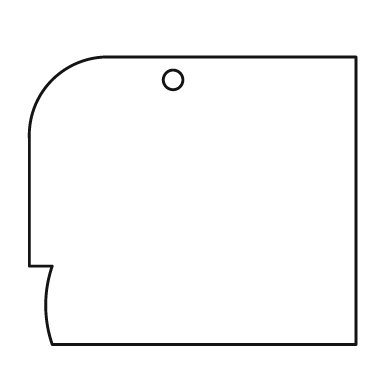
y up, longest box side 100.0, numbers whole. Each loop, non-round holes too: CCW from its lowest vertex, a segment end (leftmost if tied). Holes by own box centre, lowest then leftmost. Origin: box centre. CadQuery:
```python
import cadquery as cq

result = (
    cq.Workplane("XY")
    .moveTo(-43.0, -44.0)
    .lineTo(50.0, -44.0)
    .lineTo(50.0, 44.0)
    .lineTo(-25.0, 44.0)
    .threePointArc((-43.0, 37.0), (-50.0, 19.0))
    .lineTo(-50.0, -20.0)
    .lineTo(-43.0, -20.0)
    .threePointArc((-45.0, -32.0), (-43.0, -44.0))
    .close()
    .moveTo(-6.0, 37.0)
    .circle(3.0)
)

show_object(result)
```